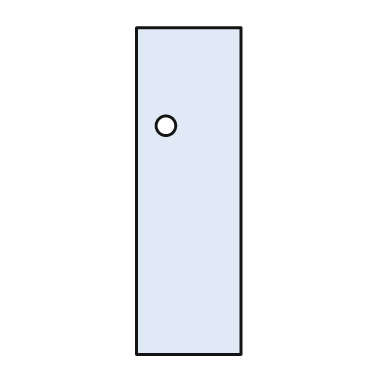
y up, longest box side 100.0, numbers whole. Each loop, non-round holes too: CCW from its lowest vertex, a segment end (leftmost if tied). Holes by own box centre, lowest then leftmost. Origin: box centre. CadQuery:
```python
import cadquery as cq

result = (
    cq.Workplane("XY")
    .moveTo(-16.0, -50.0)
    .lineTo(16.0, -50.0)
    .lineTo(16.0, 50.0)
    .lineTo(-16.0, 50.0)
    .close()
    .moveTo(-7.0, 20.0)
    .circle(3.0)
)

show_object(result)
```